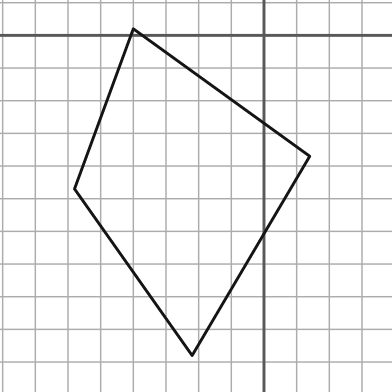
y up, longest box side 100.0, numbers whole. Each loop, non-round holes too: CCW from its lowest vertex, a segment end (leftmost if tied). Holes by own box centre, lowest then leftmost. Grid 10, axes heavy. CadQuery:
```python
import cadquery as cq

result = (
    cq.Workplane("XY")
    .moveTo(-22.0, -98.0)
    .lineTo(14.0, -37.0)
    .lineTo(-40.0, 2.0)
    .lineTo(-58.0, -47.0)
    .close()
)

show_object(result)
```